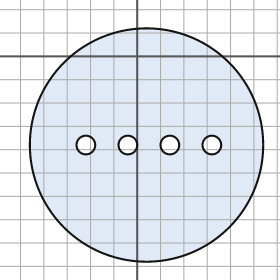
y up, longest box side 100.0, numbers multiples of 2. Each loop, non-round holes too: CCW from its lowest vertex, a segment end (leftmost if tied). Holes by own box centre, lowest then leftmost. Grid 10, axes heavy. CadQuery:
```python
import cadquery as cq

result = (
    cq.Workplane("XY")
    .moveTo(4.0, -38.0)
    .circle(50.0)
    .moveTo(-22.0, -38.0)
    .circle(4.0)
    .moveTo(-4.0, -38.0)
    .circle(4.0)
    .moveTo(14.0, -38.0)
    .circle(4.0)
    .moveTo(32.0, -38.0)
    .circle(4.0)
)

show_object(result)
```